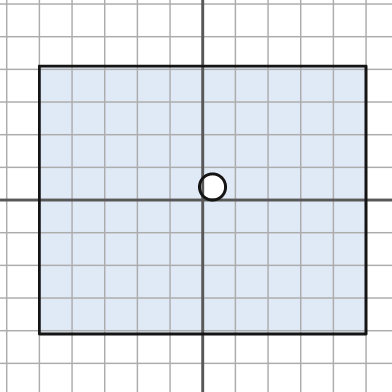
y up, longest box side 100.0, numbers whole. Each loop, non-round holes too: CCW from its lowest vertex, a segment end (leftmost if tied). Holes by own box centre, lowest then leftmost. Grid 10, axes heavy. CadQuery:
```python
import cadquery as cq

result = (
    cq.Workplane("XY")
    .moveTo(-50.0, -41.0)
    .lineTo(50.0, -41.0)
    .lineTo(50.0, 41.0)
    .lineTo(-50.0, 41.0)
    .close()
    .moveTo(3.0, 4.0)
    .circle(4.0)
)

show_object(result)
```